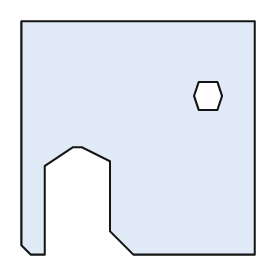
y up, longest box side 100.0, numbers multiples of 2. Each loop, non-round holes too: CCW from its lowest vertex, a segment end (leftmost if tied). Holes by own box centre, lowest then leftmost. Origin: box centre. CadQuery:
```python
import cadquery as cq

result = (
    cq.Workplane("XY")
    .moveTo(-46.0, -50.0)
    .lineTo(-40.0, -50.0)
    .lineTo(-40.0, -12.0)
    .lineTo(-28.0, -4.0)
    .lineTo(-24.0, -4.0)
    .lineTo(-12.0, -10.0)
    .lineTo(-12.0, -40.0)
    .lineTo(-2.0, -50.0)
    .lineTo(50.0, -50.0)
    .lineTo(50.0, 50.0)
    .lineTo(-50.0, 50.0)
    .lineTo(-50.0, -46.0)
    .close()
    .moveTo(26.0, 12.0)
    .lineTo(34.0, 12.0)
    .lineTo(36.0, 18.0)
    .lineTo(34.0, 24.0)
    .lineTo(26.0, 24.0)
    .lineTo(24.0, 18.0)
    .close()
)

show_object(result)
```